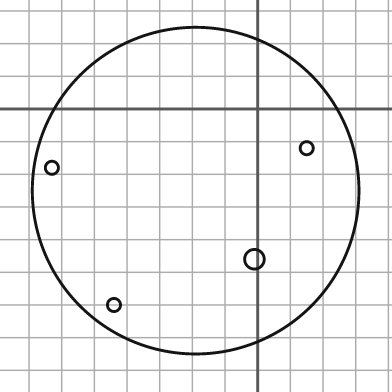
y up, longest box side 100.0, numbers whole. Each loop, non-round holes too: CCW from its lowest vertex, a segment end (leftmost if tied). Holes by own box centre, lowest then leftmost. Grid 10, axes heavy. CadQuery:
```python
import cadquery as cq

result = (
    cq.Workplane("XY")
    .moveTo(-19.0, -25.0)
    .circle(50.0)
    .moveTo(-44.0, -60.0)
    .circle(2.0)
    .moveTo(-1.0, -46.0)
    .circle(3.0)
    .moveTo(-63.0, -18.0)
    .circle(2.0)
    .moveTo(15.0, -12.0)
    .circle(2.0)
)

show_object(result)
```